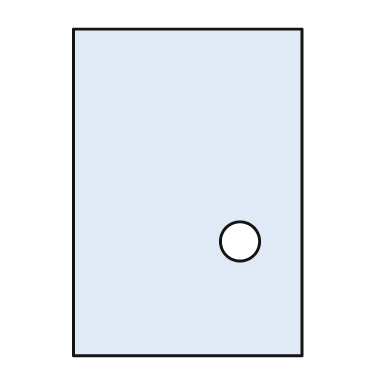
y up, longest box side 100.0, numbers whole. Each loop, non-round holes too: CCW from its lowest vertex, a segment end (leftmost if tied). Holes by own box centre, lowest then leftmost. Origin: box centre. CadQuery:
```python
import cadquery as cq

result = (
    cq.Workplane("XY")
    .moveTo(-35.0, -50.0)
    .lineTo(35.0, -50.0)
    .lineTo(35.0, 50.0)
    .lineTo(-35.0, 50.0)
    .close()
    .moveTo(16.0, -15.0)
    .circle(6.0)
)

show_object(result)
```